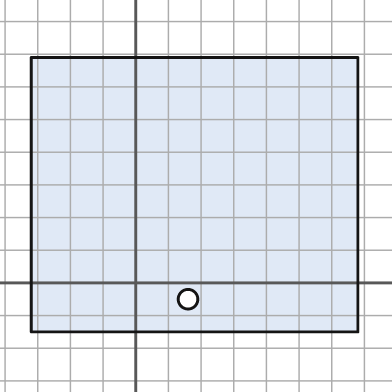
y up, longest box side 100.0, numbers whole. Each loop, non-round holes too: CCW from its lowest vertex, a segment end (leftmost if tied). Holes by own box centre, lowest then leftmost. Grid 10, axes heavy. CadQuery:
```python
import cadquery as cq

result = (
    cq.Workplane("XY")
    .moveTo(-32.0, -15.0)
    .lineTo(68.0, -15.0)
    .lineTo(68.0, 69.0)
    .lineTo(-32.0, 69.0)
    .close()
    .moveTo(16.0, -5.0)
    .circle(3.0)
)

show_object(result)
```